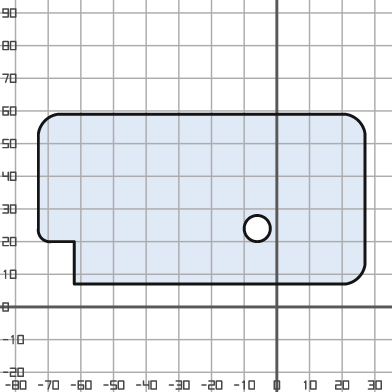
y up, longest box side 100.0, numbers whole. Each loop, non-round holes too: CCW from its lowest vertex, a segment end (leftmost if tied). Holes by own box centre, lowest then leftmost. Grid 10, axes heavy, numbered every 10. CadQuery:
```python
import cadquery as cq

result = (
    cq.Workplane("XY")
    .moveTo(-62.0, 7.0)
    .lineTo(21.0, 7.0)
    .threePointArc((25.0, 9.0), (27.0, 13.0))
    .lineTo(27.0, 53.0)
    .threePointArc((25.0, 57.0), (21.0, 59.0))
    .lineTo(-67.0, 59.0)
    .threePointArc((-71.0, 57.0), (-73.0, 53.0))
    .lineTo(-73.0, 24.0)
    .threePointArc((-72.0, 21.0), (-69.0, 20.0))
    .lineTo(-62.0, 20.0)
    .close()
    .moveTo(-6.0, 24.0)
    .circle(4.0)
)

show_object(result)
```